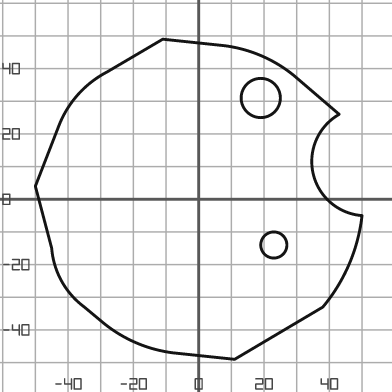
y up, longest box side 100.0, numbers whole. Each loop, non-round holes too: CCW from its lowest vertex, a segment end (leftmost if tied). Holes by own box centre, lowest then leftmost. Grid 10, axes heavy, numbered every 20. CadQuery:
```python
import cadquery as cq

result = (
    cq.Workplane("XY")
    .moveTo(11.0, -49.0)
    .lineTo(38.0, -33.0)
    .threePointArc((46.0, -20.0), (50.0, -5.0))
    .threePointArc((35.0, 8.0), (43.0, 26.0))
    .lineTo(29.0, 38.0)
    .threePointArc((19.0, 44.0), (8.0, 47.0))
    .lineTo(-11.0, 49.0)
    .lineTo(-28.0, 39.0)
    .threePointArc((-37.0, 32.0), (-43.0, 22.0))
    .lineTo(-50.0, 4.0)
    .lineTo(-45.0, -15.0)
    .threePointArc((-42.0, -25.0), (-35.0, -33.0))
    .lineTo(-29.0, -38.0)
    .threePointArc((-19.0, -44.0), (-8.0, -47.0))
    .close()
    .moveTo(23.0, -14.0)
    .circle(4.0)
    .moveTo(19.0, 31.0)
    .circle(6.0)
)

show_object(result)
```